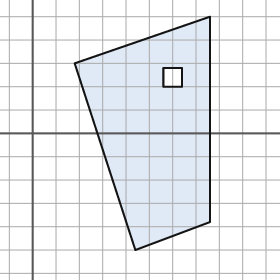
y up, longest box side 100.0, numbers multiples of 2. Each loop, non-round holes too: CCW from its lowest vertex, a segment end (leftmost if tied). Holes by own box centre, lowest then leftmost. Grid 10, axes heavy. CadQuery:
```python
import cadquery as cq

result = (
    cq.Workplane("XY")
    .moveTo(44.0, -50.0)
    .lineTo(76.0, -38.0)
    .lineTo(76.0, 50.0)
    .lineTo(18.0, 30.0)
    .close()
    .moveTo(56.0, 20.0)
    .lineTo(64.0, 20.0)
    .lineTo(64.0, 28.0)
    .lineTo(56.0, 28.0)
    .close()
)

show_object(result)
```